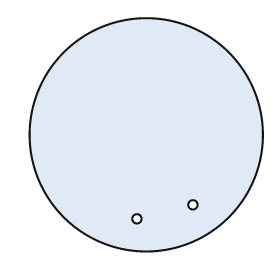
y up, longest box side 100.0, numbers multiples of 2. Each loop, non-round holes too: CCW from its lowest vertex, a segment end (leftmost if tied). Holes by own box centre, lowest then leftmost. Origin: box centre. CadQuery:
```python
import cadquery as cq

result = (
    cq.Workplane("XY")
    .moveTo(0.0, 0.0)
    .circle(50.0)
    .moveTo(-4.0, -36.0)
    .circle(2.0)
    .moveTo(20.0, -30.0)
    .circle(2.0)
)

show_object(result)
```